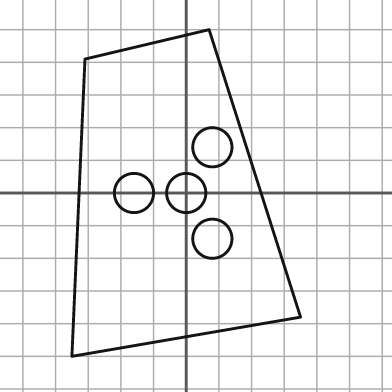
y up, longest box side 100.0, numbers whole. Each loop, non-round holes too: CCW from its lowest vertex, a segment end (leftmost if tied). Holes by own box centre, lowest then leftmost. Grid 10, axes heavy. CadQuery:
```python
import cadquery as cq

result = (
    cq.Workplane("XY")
    .moveTo(-35.0, -50.0)
    .lineTo(35.0, -38.0)
    .lineTo(7.0, 50.0)
    .lineTo(-31.0, 41.0)
    .close()
    .moveTo(8.0, -14.0)
    .circle(6.0)
    .moveTo(-16.0, 0.0)
    .circle(6.0)
    .moveTo(0.0, 0.0)
    .circle(6.0)
    .moveTo(8.0, 14.0)
    .circle(6.0)
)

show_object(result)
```